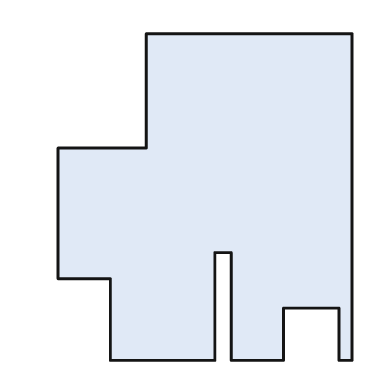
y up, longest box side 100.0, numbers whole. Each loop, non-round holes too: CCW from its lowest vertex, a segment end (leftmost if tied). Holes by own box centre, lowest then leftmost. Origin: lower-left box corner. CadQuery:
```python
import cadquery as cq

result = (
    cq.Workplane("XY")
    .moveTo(16.0, 0.0)
    .lineTo(48.0, 0.0)
    .lineTo(48.0, 33.0)
    .lineTo(53.0, 33.0)
    .lineTo(53.0, 0.0)
    .lineTo(69.0, 0.0)
    .lineTo(69.0, 16.0)
    .lineTo(86.0, 16.0)
    .lineTo(86.0, 0.0)
    .lineTo(90.0, 0.0)
    .lineTo(90.0, 100.0)
    .lineTo(27.0, 100.0)
    .lineTo(27.0, 65.0)
    .lineTo(0.0, 65.0)
    .lineTo(0.0, 25.0)
    .lineTo(16.0, 25.0)
    .close()
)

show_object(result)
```